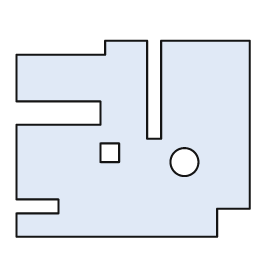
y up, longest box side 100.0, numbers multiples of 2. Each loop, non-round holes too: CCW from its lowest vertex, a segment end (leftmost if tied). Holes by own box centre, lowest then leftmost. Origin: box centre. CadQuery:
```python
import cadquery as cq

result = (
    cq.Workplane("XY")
    .moveTo(-50.0, -42.0)
    .lineTo(36.0, -42.0)
    .lineTo(36.0, -30.0)
    .lineTo(50.0, -30.0)
    .lineTo(50.0, 42.0)
    .lineTo(12.0, 42.0)
    .lineTo(12.0, 0.0)
    .lineTo(6.0, 0.0)
    .lineTo(6.0, 42.0)
    .lineTo(-12.0, 42.0)
    .lineTo(-12.0, 36.0)
    .lineTo(-50.0, 36.0)
    .lineTo(-50.0, 16.0)
    .lineTo(-14.0, 16.0)
    .lineTo(-14.0, 6.0)
    .lineTo(-50.0, 6.0)
    .lineTo(-50.0, -26.0)
    .lineTo(-32.0, -26.0)
    .lineTo(-32.0, -32.0)
    .lineTo(-50.0, -32.0)
    .close()
    .moveTo(22.0, -10.0)
    .circle(6.0)
    .moveTo(-14.0, -10.0)
    .lineTo(-6.0, -10.0)
    .lineTo(-6.0, -2.0)
    .lineTo(-14.0, -2.0)
    .close()
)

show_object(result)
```